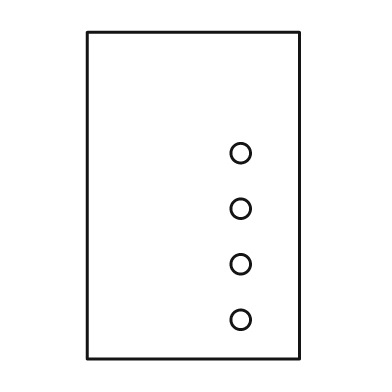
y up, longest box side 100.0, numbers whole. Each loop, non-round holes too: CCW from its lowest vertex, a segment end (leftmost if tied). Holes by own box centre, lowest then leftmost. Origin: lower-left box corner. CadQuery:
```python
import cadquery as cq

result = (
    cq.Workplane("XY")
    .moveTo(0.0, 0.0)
    .lineTo(65.0, 0.0)
    .lineTo(65.0, 100.0)
    .lineTo(0.0, 100.0)
    .close()
    .moveTo(47.0, 12.0)
    .circle(3.0)
    .moveTo(47.0, 29.0)
    .circle(3.0)
    .moveTo(47.0, 46.0)
    .circle(3.0)
    .moveTo(47.0, 63.0)
    .circle(3.0)
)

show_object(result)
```